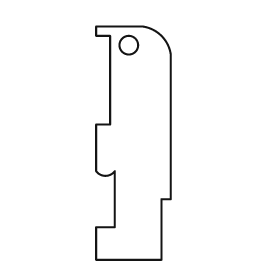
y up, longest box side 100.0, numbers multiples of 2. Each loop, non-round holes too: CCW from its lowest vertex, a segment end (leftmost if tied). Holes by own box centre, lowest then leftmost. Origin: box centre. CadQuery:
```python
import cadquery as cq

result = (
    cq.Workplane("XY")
    .moveTo(-16.0, -50.0)
    .lineTo(12.0, -50.0)
    .lineTo(12.0, -24.0)
    .lineTo(16.0, -24.0)
    .lineTo(16.0, 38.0)
    .threePointArc((12.0, 46.0), (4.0, 50.0))
    .lineTo(-16.0, 50.0)
    .lineTo(-16.0, 46.0)
    .lineTo(-10.0, 46.0)
    .lineTo(-10.0, 8.0)
    .lineTo(-16.0, 8.0)
    .lineTo(-16.0, -12.0)
    .threePointArc((-12.0, -14.0), (-8.0, -12.0))
    .lineTo(-8.0, -36.0)
    .lineTo(-16.0, -36.0)
    .close()
    .moveTo(-2.0, 42.0)
    .circle(4.0)
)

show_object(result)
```